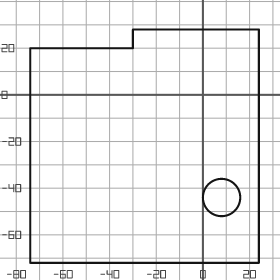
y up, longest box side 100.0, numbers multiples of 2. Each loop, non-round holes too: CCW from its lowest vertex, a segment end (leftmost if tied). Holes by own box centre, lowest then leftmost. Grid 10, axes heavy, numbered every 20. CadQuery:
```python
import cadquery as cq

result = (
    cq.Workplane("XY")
    .moveTo(-74.0, -72.0)
    .lineTo(24.0, -72.0)
    .lineTo(24.0, 28.0)
    .lineTo(-30.0, 28.0)
    .lineTo(-30.0, 20.0)
    .lineTo(-74.0, 20.0)
    .close()
    .moveTo(8.0, -44.0)
    .circle(8.0)
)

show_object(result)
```